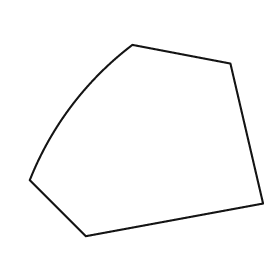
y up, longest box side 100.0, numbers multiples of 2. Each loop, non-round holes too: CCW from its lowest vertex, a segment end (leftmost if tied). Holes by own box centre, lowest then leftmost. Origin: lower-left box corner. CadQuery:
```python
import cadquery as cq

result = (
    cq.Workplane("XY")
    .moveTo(24.0, 0.0)
    .lineTo(100.0, 14.0)
    .lineTo(86.0, 74.0)
    .lineTo(44.0, 82.0)
    .threePointArc((18.0, 56.0), (0.0, 24.0))
    .close()
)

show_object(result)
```